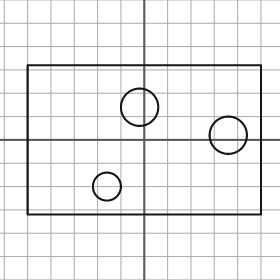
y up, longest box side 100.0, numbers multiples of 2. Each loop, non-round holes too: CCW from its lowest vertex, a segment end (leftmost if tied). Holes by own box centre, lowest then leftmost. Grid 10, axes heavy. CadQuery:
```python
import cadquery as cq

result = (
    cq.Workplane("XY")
    .moveTo(-50.0, -32.0)
    .lineTo(50.0, -32.0)
    .lineTo(50.0, 32.0)
    .lineTo(-50.0, 32.0)
    .close()
    .moveTo(-16.0, -20.0)
    .circle(6.0)
    .moveTo(36.0, 2.0)
    .circle(8.0)
    .moveTo(-2.0, 14.0)
    .circle(8.0)
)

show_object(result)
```